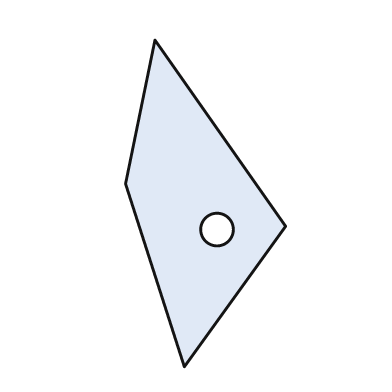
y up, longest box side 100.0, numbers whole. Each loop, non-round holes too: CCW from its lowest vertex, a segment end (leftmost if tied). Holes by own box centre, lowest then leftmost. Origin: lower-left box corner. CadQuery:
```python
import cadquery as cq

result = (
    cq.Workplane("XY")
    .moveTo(18.0, 0.0)
    .lineTo(49.0, 43.0)
    .lineTo(9.0, 100.0)
    .lineTo(0.0, 56.0)
    .close()
    .moveTo(28.0, 42.0)
    .circle(5.0)
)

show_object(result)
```